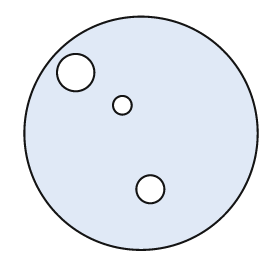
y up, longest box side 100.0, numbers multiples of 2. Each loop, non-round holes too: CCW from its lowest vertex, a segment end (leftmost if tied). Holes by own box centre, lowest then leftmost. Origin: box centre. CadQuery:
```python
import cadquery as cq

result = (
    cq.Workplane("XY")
    .moveTo(0.0, 0.0)
    .circle(50.0)
    .moveTo(4.0, -24.0)
    .circle(6.0)
    .moveTo(-8.0, 12.0)
    .circle(4.0)
    .moveTo(-28.0, 26.0)
    .circle(8.0)
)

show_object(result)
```